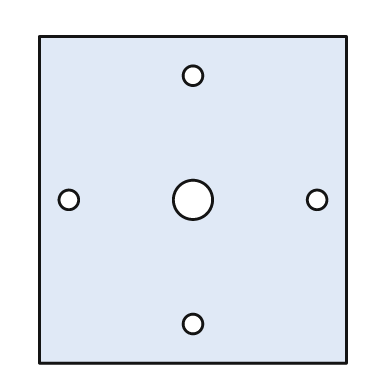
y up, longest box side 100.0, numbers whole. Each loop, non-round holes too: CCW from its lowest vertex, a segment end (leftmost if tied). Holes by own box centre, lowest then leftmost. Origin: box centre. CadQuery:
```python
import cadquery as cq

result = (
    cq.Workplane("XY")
    .moveTo(-47.0, -50.0)
    .lineTo(47.0, -50.0)
    .lineTo(47.0, 50.0)
    .lineTo(-47.0, 50.0)
    .close()
    .moveTo(0.0, -38.0)
    .circle(3.0)
    .moveTo(-38.0, 0.0)
    .circle(3.0)
    .moveTo(0.0, 0.0)
    .circle(6.0)
    .moveTo(38.0, 0.0)
    .circle(3.0)
    .moveTo(0.0, 38.0)
    .circle(3.0)
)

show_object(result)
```